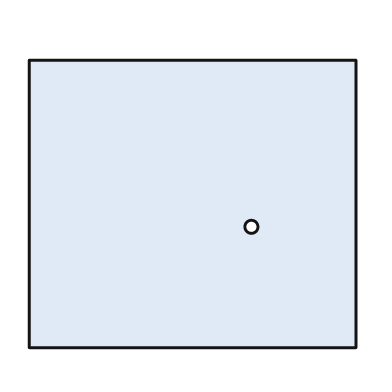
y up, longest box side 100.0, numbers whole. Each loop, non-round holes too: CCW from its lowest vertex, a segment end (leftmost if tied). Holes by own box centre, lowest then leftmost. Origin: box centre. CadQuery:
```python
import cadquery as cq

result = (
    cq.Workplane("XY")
    .moveTo(-50.0, -44.0)
    .lineTo(50.0, -44.0)
    .lineTo(50.0, 44.0)
    .lineTo(-50.0, 44.0)
    .close()
    .moveTo(18.0, -7.0)
    .circle(2.0)
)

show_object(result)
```